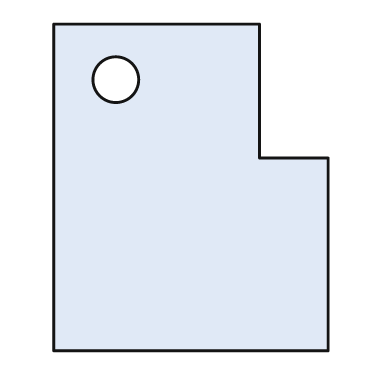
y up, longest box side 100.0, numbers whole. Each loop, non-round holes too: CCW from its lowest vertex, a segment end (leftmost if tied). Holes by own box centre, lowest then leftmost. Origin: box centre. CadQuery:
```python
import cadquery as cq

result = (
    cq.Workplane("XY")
    .moveTo(-42.0, -50.0)
    .lineTo(42.0, -50.0)
    .lineTo(42.0, 9.0)
    .lineTo(21.0, 9.0)
    .lineTo(21.0, 50.0)
    .lineTo(-42.0, 50.0)
    .close()
    .moveTo(-23.0, 33.0)
    .circle(7.0)
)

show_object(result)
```